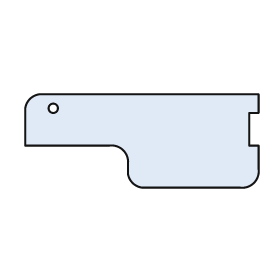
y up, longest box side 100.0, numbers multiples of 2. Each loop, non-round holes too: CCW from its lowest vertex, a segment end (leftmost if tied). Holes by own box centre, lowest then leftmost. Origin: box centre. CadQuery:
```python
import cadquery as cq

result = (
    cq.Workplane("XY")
    .moveTo(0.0, -20.0)
    .lineTo(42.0, -20.0)
    .threePointArc((48.0, -18.0), (50.0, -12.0))
    .lineTo(50.0, -2.0)
    .lineTo(46.0, -2.0)
    .lineTo(46.0, 12.0)
    .lineTo(50.0, 12.0)
    .lineTo(50.0, 20.0)
    .lineTo(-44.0, 20.0)
    .threePointArc((-48.0, 18.0), (-50.0, 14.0))
    .lineTo(-50.0, -2.0)
    .lineTo(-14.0, -2.0)
    .threePointArc((-8.0, -4.0), (-6.0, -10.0))
    .lineTo(-6.0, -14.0)
    .threePointArc((-4.0, -18.0), (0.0, -20.0))
    .close()
    .moveTo(-38.0, 14.0)
    .circle(2.0)
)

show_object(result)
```